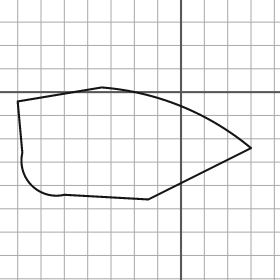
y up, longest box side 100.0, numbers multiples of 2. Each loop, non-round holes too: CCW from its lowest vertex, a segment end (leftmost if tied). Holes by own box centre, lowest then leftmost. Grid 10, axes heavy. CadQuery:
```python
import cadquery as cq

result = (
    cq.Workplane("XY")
    .moveTo(-14.0, -46.0)
    .lineTo(30.0, -24.0)
    .threePointArc((0.0, -6.0), (-34.0, 2.0))
    .lineTo(-70.0, -4.0)
    .lineTo(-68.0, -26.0)
    .threePointArc((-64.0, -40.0), (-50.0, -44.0))
    .close()
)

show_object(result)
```